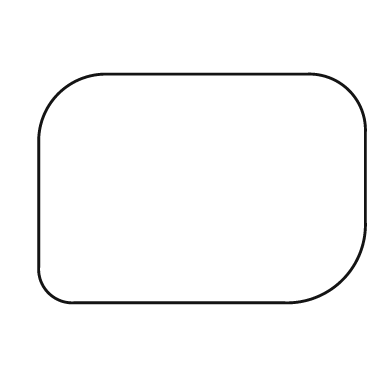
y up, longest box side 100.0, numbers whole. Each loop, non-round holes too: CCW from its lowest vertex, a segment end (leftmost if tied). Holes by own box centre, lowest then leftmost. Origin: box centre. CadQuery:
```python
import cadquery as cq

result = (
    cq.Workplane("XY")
    .moveTo(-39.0, -35.0)
    .lineTo(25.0, -35.0)
    .threePointArc((43.0, -28.0), (50.0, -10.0))
    .lineTo(50.0, 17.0)
    .threePointArc((45.0, 30.0), (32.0, 35.0))
    .lineTo(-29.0, 35.0)
    .threePointArc((-44.0, 29.0), (-50.0, 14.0))
    .lineTo(-50.0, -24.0)
    .threePointArc((-47.0, -32.0), (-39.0, -35.0))
    .close()
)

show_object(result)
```